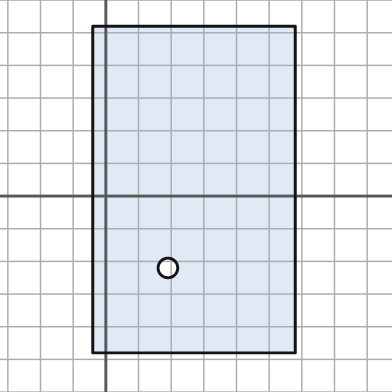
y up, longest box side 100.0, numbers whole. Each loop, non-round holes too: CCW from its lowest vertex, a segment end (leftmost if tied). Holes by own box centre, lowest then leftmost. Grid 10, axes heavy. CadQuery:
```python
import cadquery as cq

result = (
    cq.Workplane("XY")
    .moveTo(-4.0, -48.0)
    .lineTo(58.0, -48.0)
    .lineTo(58.0, 52.0)
    .lineTo(-4.0, 52.0)
    .close()
    .moveTo(19.0, -22.0)
    .circle(3.0)
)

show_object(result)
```